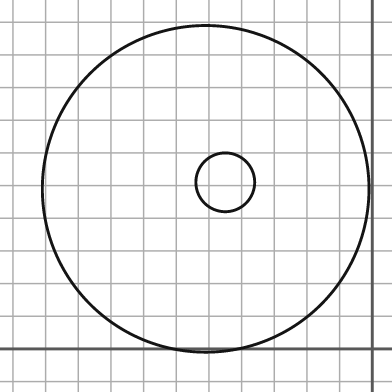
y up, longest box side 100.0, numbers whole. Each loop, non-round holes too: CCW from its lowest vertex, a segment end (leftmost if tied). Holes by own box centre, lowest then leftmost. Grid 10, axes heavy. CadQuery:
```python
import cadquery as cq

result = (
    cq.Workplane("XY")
    .moveTo(-51.0, 49.0)
    .circle(50.0)
    .moveTo(-45.0, 51.0)
    .circle(9.0)
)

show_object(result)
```